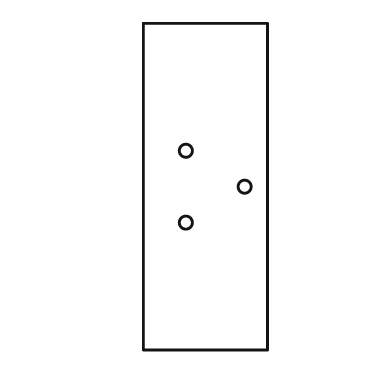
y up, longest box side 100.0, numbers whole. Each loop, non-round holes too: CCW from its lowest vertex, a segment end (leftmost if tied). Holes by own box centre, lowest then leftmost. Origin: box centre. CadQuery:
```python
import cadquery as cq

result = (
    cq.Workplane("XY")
    .moveTo(-19.0, -50.0)
    .lineTo(19.0, -50.0)
    .lineTo(19.0, 50.0)
    .lineTo(-19.0, 50.0)
    .close()
    .moveTo(-6.0, -11.0)
    .circle(2.0)
    .moveTo(12.0, 0.0)
    .circle(2.0)
    .moveTo(-6.0, 11.0)
    .circle(2.0)
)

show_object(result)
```